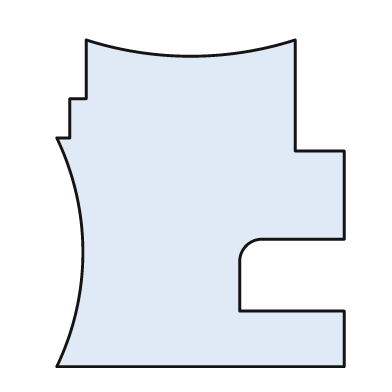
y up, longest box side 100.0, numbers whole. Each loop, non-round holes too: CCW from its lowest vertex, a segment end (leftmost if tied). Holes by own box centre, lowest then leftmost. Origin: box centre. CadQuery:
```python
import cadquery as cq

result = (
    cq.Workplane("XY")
    .moveTo(-44.0, -50.0)
    .lineTo(44.0, -50.0)
    .lineTo(44.0, -33.0)
    .lineTo(12.0, -33.0)
    .lineTo(12.0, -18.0)
    .threePointArc((14.0, -13.0), (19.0, -11.0))
    .lineTo(44.0, -11.0)
    .lineTo(44.0, 16.0)
    .lineTo(29.0, 16.0)
    .lineTo(29.0, 50.0)
    .threePointArc((-3.0, 45.0), (-35.0, 50.0))
    .lineTo(-35.0, 32.0)
    .lineTo(-40.0, 32.0)
    .lineTo(-40.0, 20.0)
    .lineTo(-44.0, 20.0)
    .threePointArc((-36.0, -15.0), (-44.0, -50.0))
    .close()
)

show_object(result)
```